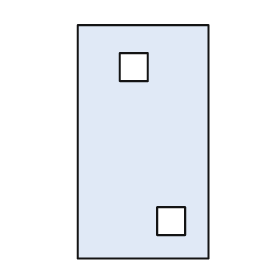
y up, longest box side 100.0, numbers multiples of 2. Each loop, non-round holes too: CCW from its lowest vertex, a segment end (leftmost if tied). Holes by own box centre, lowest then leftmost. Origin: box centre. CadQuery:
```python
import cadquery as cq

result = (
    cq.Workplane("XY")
    .moveTo(-28.0, -50.0)
    .lineTo(28.0, -50.0)
    .lineTo(28.0, 50.0)
    .lineTo(-28.0, 50.0)
    .close()
    .moveTo(6.0, -40.0)
    .lineTo(18.0, -40.0)
    .lineTo(18.0, -28.0)
    .lineTo(6.0, -28.0)
    .close()
    .moveTo(-10.0, 26.0)
    .lineTo(2.0, 26.0)
    .lineTo(2.0, 38.0)
    .lineTo(-10.0, 38.0)
    .close()
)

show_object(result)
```